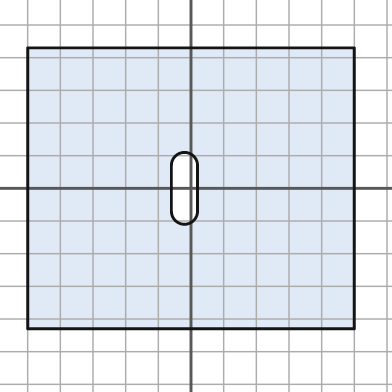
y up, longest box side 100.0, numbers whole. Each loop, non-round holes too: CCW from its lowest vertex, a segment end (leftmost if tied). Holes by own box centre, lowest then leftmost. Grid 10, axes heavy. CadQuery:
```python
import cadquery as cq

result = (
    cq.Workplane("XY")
    .moveTo(-50.0, -43.0)
    .lineTo(50.0, -43.0)
    .lineTo(50.0, 43.0)
    .lineTo(-50.0, 43.0)
    .close()
    .moveTo(-6.0, -7.0)
    .threePointArc((-2.0, -11.0), (2.0, -7.0))
    .lineTo(2.0, 7.0)
    .threePointArc((-2.0, 11.0), (-6.0, 7.0))
    .close()
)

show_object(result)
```